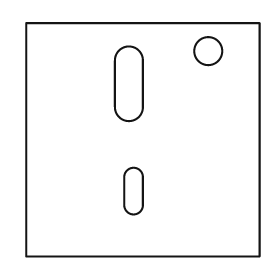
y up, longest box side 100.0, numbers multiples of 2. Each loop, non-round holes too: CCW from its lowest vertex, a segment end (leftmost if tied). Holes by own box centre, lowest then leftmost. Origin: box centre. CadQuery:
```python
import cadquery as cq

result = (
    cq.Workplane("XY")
    .moveTo(-50.0, -50.0)
    .lineTo(50.0, -50.0)
    .lineTo(50.0, 50.0)
    .lineTo(-50.0, 50.0)
    .close()
    .moveTo(-8.0, -28.0)
    .threePointArc((-4.0, -32.0), (0.0, -28.0))
    .lineTo(0.0, -16.0)
    .threePointArc((-4.0, -12.0), (-8.0, -16.0))
    .close()
    .moveTo(-12.0, 14.0)
    .threePointArc((-6.0, 8.0), (0.0, 14.0))
    .lineTo(0.0, 34.0)
    .threePointArc((-6.0, 40.0), (-12.0, 34.0))
    .close()
    .moveTo(28.0, 38.0)
    .circle(6.0)
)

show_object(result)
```